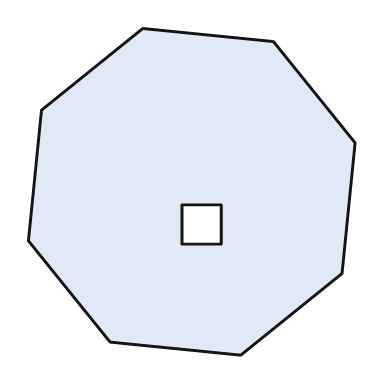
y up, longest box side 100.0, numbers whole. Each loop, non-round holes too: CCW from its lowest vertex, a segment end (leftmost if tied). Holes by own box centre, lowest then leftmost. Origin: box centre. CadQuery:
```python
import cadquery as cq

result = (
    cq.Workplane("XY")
    .moveTo(15.0, -50.0)
    .lineTo(46.0, -25.0)
    .lineTo(50.0, 15.0)
    .lineTo(25.0, 46.0)
    .lineTo(-15.0, 50.0)
    .lineTo(-46.0, 25.0)
    .lineTo(-50.0, -15.0)
    .lineTo(-25.0, -46.0)
    .close()
    .moveTo(-3.0, -16.0)
    .lineTo(9.0, -16.0)
    .lineTo(9.0, -4.0)
    .lineTo(-3.0, -4.0)
    .close()
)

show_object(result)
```